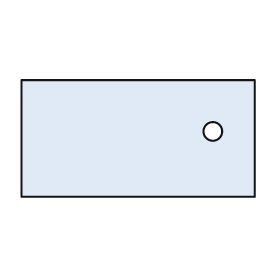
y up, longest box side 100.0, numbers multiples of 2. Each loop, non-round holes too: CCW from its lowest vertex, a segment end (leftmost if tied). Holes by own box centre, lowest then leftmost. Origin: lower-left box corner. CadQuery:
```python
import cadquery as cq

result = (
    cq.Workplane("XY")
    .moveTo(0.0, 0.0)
    .lineTo(100.0, 0.0)
    .lineTo(100.0, 50.0)
    .lineTo(0.0, 50.0)
    .close()
    .moveTo(82.0, 28.0)
    .circle(4.0)
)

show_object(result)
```